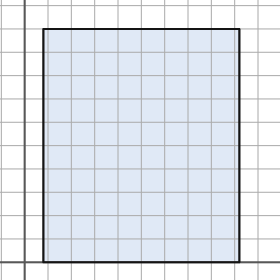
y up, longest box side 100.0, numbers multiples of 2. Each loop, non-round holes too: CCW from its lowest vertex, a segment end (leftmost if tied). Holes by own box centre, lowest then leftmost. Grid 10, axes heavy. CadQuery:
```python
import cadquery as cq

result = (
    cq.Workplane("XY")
    .moveTo(8.0, 0.0)
    .lineTo(92.0, 0.0)
    .lineTo(92.0, 100.0)
    .lineTo(8.0, 100.0)
    .close()
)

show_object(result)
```